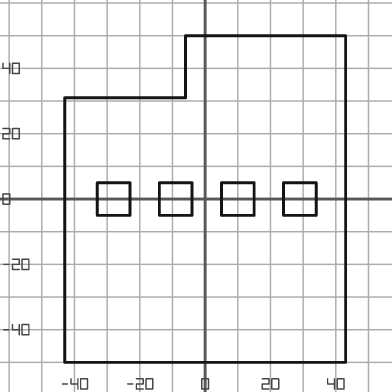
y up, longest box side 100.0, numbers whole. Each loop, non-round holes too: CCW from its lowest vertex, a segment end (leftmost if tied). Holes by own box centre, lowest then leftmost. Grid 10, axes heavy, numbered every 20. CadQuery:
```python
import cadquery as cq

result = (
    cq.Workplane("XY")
    .moveTo(-43.0, -50.0)
    .lineTo(43.0, -50.0)
    .lineTo(43.0, 50.0)
    .lineTo(-6.0, 50.0)
    .lineTo(-6.0, 31.0)
    .lineTo(-43.0, 31.0)
    .close()
    .moveTo(-33.0, -5.0)
    .lineTo(-23.0, -5.0)
    .lineTo(-23.0, 5.0)
    .lineTo(-33.0, 5.0)
    .close()
    .moveTo(-14.0, -5.0)
    .lineTo(-4.0, -5.0)
    .lineTo(-4.0, 5.0)
    .lineTo(-14.0, 5.0)
    .close()
    .moveTo(5.0, -5.0)
    .lineTo(15.0, -5.0)
    .lineTo(15.0, 5.0)
    .lineTo(5.0, 5.0)
    .close()
    .moveTo(24.0, -5.0)
    .lineTo(34.0, -5.0)
    .lineTo(34.0, 5.0)
    .lineTo(24.0, 5.0)
    .close()
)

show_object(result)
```